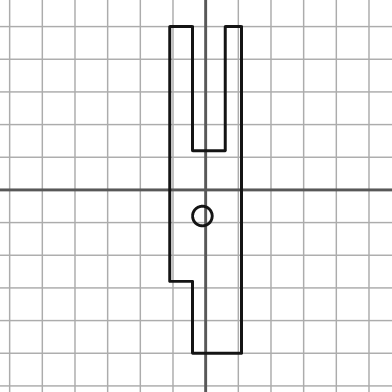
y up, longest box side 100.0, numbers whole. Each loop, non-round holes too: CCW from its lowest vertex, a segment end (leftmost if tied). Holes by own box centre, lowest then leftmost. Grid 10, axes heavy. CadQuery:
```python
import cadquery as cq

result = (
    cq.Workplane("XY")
    .moveTo(-4.0, -50.0)
    .lineTo(11.0, -50.0)
    .lineTo(11.0, 50.0)
    .lineTo(6.0, 50.0)
    .lineTo(6.0, 12.0)
    .lineTo(-4.0, 12.0)
    .lineTo(-4.0, 50.0)
    .lineTo(-11.0, 50.0)
    .lineTo(-11.0, -28.0)
    .lineTo(-4.0, -28.0)
    .close()
    .moveTo(-1.0, -8.0)
    .circle(3.0)
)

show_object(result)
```